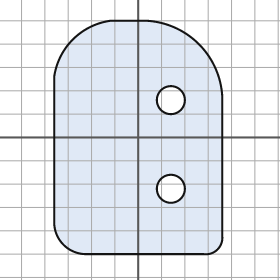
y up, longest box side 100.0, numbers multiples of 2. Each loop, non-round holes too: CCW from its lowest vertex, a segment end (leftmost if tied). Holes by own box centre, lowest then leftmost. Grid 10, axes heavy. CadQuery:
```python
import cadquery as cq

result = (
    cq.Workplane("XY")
    .moveTo(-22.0, -50.0)
    .lineTo(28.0, -50.0)
    .threePointArc((34.0, -48.0), (36.0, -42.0))
    .lineTo(36.0, 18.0)
    .threePointArc((26.0, 40.0), (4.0, 50.0))
    .lineTo(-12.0, 50.0)
    .threePointArc((-28.0, 42.0), (-36.0, 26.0))
    .lineTo(-36.0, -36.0)
    .threePointArc((-32.0, -46.0), (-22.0, -50.0))
    .close()
    .moveTo(14.0, -22.0)
    .circle(6.0)
    .moveTo(14.0, 16.0)
    .circle(6.0)
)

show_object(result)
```